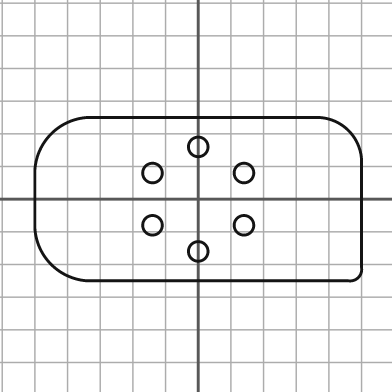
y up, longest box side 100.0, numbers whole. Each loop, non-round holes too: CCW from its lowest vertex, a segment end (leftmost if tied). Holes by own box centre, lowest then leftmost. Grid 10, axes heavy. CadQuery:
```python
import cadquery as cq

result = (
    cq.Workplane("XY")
    .moveTo(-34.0, -25.0)
    .lineTo(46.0, -25.0)
    .threePointArc((49.0, -24.0), (50.0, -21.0))
    .lineTo(50.0, 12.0)
    .threePointArc((46.0, 21.0), (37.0, 25.0))
    .lineTo(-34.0, 25.0)
    .threePointArc((-45.0, 20.0), (-50.0, 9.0))
    .lineTo(-50.0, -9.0)
    .threePointArc((-45.0, -20.0), (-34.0, -25.0))
    .close()
    .moveTo(0.0, -16.0)
    .circle(3.0)
    .moveTo(-14.0, -8.0)
    .circle(3.0)
    .moveTo(14.0, -8.0)
    .circle(3.0)
    .moveTo(-14.0, 8.0)
    .circle(3.0)
    .moveTo(14.0, 8.0)
    .circle(3.0)
    .moveTo(0.0, 16.0)
    .circle(3.0)
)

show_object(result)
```